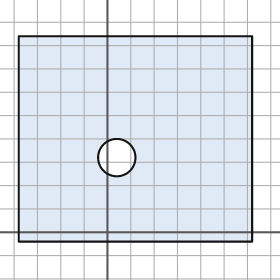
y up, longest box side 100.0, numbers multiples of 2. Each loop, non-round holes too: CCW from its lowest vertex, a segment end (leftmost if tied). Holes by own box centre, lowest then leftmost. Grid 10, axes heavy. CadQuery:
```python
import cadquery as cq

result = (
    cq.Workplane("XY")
    .moveTo(-38.0, -4.0)
    .lineTo(62.0, -4.0)
    .lineTo(62.0, 84.0)
    .lineTo(-38.0, 84.0)
    .close()
    .moveTo(4.0, 32.0)
    .circle(8.0)
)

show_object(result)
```